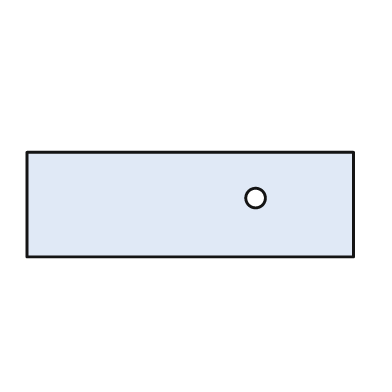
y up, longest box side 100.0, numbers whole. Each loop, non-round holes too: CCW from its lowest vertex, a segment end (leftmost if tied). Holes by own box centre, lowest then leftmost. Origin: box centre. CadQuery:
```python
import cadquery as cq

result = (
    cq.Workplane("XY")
    .moveTo(-50.0, -16.0)
    .lineTo(50.0, -16.0)
    .lineTo(50.0, 16.0)
    .lineTo(-50.0, 16.0)
    .close()
    .moveTo(20.0, 2.0)
    .circle(3.0)
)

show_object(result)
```